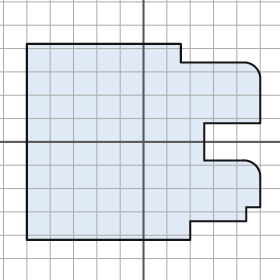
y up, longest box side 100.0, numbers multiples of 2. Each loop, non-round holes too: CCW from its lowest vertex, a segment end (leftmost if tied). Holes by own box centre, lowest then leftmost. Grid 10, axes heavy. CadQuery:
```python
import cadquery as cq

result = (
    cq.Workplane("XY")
    .moveTo(-50.0, -42.0)
    .lineTo(20.0, -42.0)
    .lineTo(20.0, -34.0)
    .lineTo(44.0, -34.0)
    .lineTo(44.0, -28.0)
    .lineTo(50.0, -28.0)
    .lineTo(50.0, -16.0)
    .threePointArc((48.0, -10.0), (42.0, -8.0))
    .lineTo(26.0, -8.0)
    .lineTo(26.0, 8.0)
    .lineTo(50.0, 8.0)
    .lineTo(50.0, 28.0)
    .threePointArc((48.0, 32.0), (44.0, 34.0))
    .lineTo(16.0, 34.0)
    .lineTo(16.0, 42.0)
    .lineTo(-50.0, 42.0)
    .close()
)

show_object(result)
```